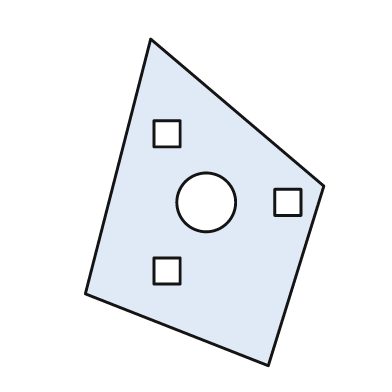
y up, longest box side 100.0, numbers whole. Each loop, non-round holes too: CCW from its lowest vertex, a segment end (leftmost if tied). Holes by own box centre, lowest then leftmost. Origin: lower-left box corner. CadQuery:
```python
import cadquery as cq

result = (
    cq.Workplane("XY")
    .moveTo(56.0, 0.0)
    .lineTo(73.0, 55.0)
    .lineTo(20.0, 100.0)
    .lineTo(0.0, 22.0)
    .close()
    .moveTo(21.0, 25.0)
    .lineTo(29.0, 25.0)
    .lineTo(29.0, 33.0)
    .lineTo(21.0, 33.0)
    .close()
    .moveTo(37.0, 50.0)
    .circle(9.0)
    .moveTo(58.0, 46.0)
    .lineTo(66.0, 46.0)
    .lineTo(66.0, 54.0)
    .lineTo(58.0, 54.0)
    .close()
    .moveTo(21.0, 67.0)
    .lineTo(29.0, 67.0)
    .lineTo(29.0, 75.0)
    .lineTo(21.0, 75.0)
    .close()
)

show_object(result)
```